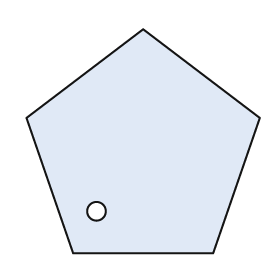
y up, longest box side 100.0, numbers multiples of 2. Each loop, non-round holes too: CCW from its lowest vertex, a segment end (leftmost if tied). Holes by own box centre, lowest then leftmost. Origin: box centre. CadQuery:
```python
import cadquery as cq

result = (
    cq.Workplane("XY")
    .moveTo(-30.0, -48.0)
    .lineTo(30.0, -48.0)
    .lineTo(50.0, 10.0)
    .lineTo(0.0, 48.0)
    .lineTo(-50.0, 10.0)
    .close()
    .moveTo(-20.0, -30.0)
    .circle(4.0)
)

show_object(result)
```